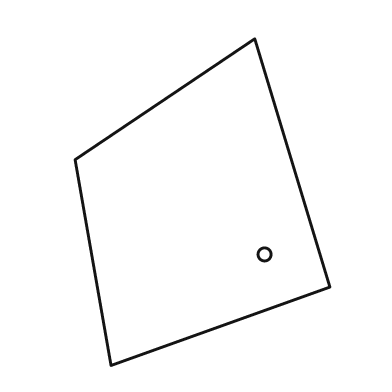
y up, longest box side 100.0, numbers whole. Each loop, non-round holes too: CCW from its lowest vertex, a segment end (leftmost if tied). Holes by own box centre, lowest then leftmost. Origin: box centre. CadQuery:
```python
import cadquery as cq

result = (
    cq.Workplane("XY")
    .moveTo(-28.0, -50.0)
    .lineTo(39.0, -26.0)
    .lineTo(16.0, 50.0)
    .lineTo(-39.0, 13.0)
    .close()
    .moveTo(19.0, -16.0)
    .circle(2.0)
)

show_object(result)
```